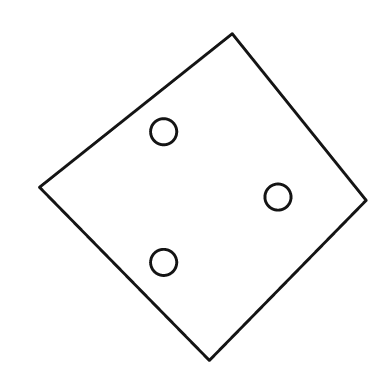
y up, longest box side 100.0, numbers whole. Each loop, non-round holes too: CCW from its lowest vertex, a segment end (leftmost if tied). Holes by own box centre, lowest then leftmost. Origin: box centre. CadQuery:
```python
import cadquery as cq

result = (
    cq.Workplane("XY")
    .moveTo(2.0, -50.0)
    .lineTo(50.0, -1.0)
    .lineTo(9.0, 50.0)
    .lineTo(-50.0, 3.0)
    .close()
    .moveTo(-12.0, -20.0)
    .circle(4.0)
    .moveTo(23.0, 0.0)
    .circle(4.0)
    .moveTo(-12.0, 20.0)
    .circle(4.0)
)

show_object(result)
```